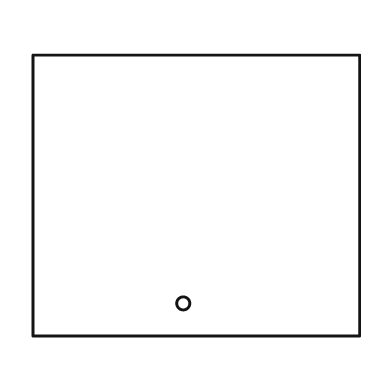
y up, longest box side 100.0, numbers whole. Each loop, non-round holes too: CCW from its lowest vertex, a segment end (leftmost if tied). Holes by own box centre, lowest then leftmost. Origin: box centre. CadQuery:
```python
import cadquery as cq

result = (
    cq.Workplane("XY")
    .moveTo(-50.0, -43.0)
    .lineTo(50.0, -43.0)
    .lineTo(50.0, 43.0)
    .lineTo(-50.0, 43.0)
    .close()
    .moveTo(-4.0, -33.0)
    .circle(2.0)
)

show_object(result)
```